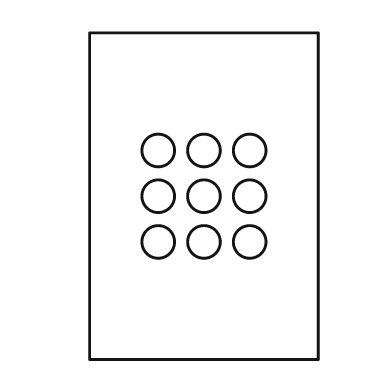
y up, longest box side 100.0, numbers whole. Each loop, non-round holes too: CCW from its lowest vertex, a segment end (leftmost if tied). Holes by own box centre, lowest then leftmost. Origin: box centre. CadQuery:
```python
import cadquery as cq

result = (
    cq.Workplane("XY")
    .moveTo(-35.0, -50.0)
    .lineTo(35.0, -50.0)
    .lineTo(35.0, 50.0)
    .lineTo(-35.0, 50.0)
    .close()
    .moveTo(-14.0, -14.0)
    .circle(5.0)
    .moveTo(0.0, -14.0)
    .circle(5.0)
    .moveTo(14.0, -14.0)
    .circle(5.0)
    .moveTo(-14.0, 0.0)
    .circle(5.0)
    .moveTo(0.0, 0.0)
    .circle(5.0)
    .moveTo(14.0, 0.0)
    .circle(5.0)
    .moveTo(-14.0, 14.0)
    .circle(5.0)
    .moveTo(0.0, 14.0)
    .circle(5.0)
    .moveTo(14.0, 14.0)
    .circle(5.0)
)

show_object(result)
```